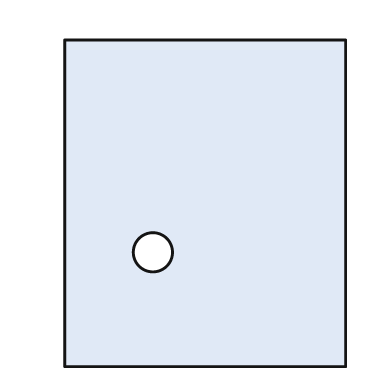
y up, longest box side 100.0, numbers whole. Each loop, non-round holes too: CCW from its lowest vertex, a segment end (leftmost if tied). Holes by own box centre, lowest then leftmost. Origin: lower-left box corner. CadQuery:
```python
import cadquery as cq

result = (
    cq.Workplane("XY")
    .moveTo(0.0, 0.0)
    .lineTo(86.0, 0.0)
    .lineTo(86.0, 100.0)
    .lineTo(0.0, 100.0)
    .close()
    .moveTo(27.0, 35.0)
    .circle(6.0)
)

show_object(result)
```